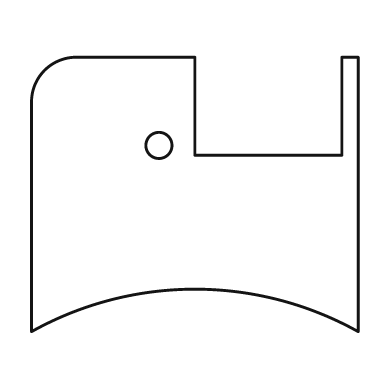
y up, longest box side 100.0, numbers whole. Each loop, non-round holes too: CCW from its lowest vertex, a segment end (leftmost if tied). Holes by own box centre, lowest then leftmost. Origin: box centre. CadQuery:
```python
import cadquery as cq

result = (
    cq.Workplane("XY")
    .moveTo(-50.0, -42.0)
    .threePointArc((0.0, -29.0), (50.0, -42.0))
    .lineTo(50.0, 42.0)
    .lineTo(45.0, 42.0)
    .lineTo(45.0, 12.0)
    .lineTo(0.0, 12.0)
    .lineTo(0.0, 42.0)
    .lineTo(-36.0, 42.0)
    .threePointArc((-46.0, 38.0), (-50.0, 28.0))
    .close()
    .moveTo(-11.0, 15.0)
    .circle(4.0)
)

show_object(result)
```